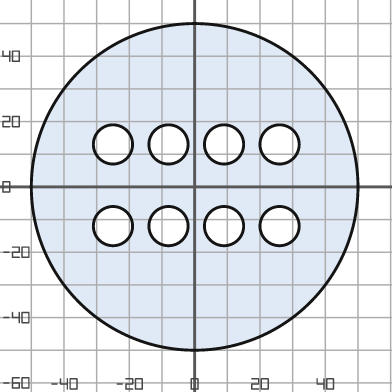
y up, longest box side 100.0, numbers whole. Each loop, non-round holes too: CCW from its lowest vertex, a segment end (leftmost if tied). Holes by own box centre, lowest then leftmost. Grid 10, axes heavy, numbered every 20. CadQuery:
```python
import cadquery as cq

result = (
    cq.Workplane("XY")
    .moveTo(0.0, 0.0)
    .circle(50.0)
    .moveTo(-25.0, -12.0)
    .circle(6.0)
    .moveTo(-8.0, -12.0)
    .circle(6.0)
    .moveTo(9.0, -12.0)
    .circle(6.0)
    .moveTo(26.0, -12.0)
    .circle(6.0)
    .moveTo(-25.0, 13.0)
    .circle(6.0)
    .moveTo(-8.0, 13.0)
    .circle(6.0)
    .moveTo(9.0, 13.0)
    .circle(6.0)
    .moveTo(26.0, 13.0)
    .circle(6.0)
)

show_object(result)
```